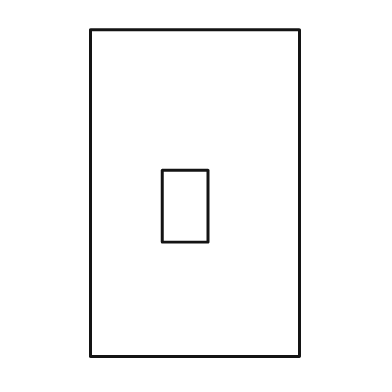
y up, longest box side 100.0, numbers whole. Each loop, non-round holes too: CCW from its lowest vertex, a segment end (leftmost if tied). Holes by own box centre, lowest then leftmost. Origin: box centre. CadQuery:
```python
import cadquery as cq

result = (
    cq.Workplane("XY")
    .moveTo(-32.0, -50.0)
    .lineTo(32.0, -50.0)
    .lineTo(32.0, 50.0)
    .lineTo(-32.0, 50.0)
    .close()
    .moveTo(-10.0, -15.0)
    .lineTo(4.0, -15.0)
    .lineTo(4.0, 7.0)
    .lineTo(-10.0, 7.0)
    .close()
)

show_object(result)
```